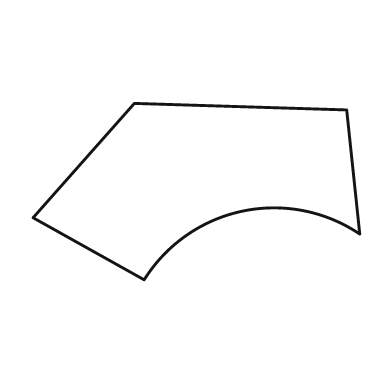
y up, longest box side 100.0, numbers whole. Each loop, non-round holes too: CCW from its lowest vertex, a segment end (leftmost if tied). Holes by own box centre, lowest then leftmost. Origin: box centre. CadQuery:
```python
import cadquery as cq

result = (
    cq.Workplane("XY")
    .moveTo(-16.0, -27.0)
    .threePointArc((14.0, -6.0), (50.0, -13.0))
    .lineTo(46.0, 25.0)
    .lineTo(-19.0, 27.0)
    .lineTo(-50.0, -8.0)
    .close()
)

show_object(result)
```